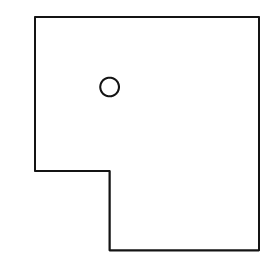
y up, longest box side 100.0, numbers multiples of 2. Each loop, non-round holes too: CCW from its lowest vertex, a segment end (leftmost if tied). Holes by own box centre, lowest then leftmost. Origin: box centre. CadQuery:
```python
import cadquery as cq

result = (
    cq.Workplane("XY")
    .moveTo(-16.0, -50.0)
    .lineTo(48.0, -50.0)
    .lineTo(48.0, 50.0)
    .lineTo(-48.0, 50.0)
    .lineTo(-48.0, -16.0)
    .lineTo(-16.0, -16.0)
    .close()
    .moveTo(-16.0, 20.0)
    .circle(4.0)
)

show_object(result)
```